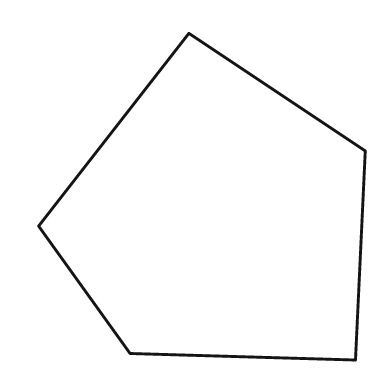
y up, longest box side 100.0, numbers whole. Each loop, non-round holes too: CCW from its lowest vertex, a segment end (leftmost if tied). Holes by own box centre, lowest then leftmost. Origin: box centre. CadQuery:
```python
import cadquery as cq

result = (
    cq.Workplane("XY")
    .moveTo(47.0, -50.0)
    .lineTo(50.0, 14.0)
    .lineTo(-4.0, 50.0)
    .lineTo(-50.0, -9.0)
    .lineTo(-22.0, -48.0)
    .close()
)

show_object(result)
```